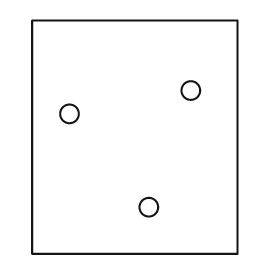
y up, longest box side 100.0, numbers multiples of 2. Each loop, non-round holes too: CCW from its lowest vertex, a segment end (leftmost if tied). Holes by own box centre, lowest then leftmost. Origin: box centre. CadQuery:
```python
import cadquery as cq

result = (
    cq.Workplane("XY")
    .moveTo(-44.0, -50.0)
    .lineTo(44.0, -50.0)
    .lineTo(44.0, 50.0)
    .lineTo(-44.0, 50.0)
    .close()
    .moveTo(6.0, -30.0)
    .circle(4.0)
    .moveTo(-28.0, 10.0)
    .circle(4.0)
    .moveTo(24.0, 20.0)
    .circle(4.0)
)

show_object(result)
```